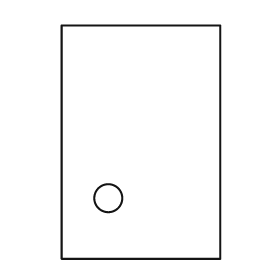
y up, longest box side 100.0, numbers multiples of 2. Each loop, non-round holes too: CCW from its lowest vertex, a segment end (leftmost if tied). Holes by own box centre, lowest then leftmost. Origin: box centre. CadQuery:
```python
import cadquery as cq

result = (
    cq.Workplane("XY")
    .moveTo(-34.0, -50.0)
    .lineTo(34.0, -50.0)
    .lineTo(34.0, 50.0)
    .lineTo(-34.0, 50.0)
    .close()
    .moveTo(-14.0, -24.0)
    .circle(6.0)
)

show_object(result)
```